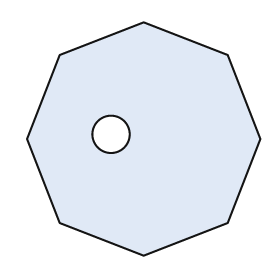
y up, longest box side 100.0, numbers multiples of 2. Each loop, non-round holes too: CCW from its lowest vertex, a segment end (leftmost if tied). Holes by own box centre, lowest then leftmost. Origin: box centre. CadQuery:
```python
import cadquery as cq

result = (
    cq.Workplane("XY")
    .moveTo(0.0, -50.0)
    .lineTo(36.0, -36.0)
    .lineTo(50.0, 0.0)
    .lineTo(36.0, 36.0)
    .lineTo(0.0, 50.0)
    .lineTo(-36.0, 36.0)
    .lineTo(-50.0, 0.0)
    .lineTo(-36.0, -36.0)
    .close()
    .moveTo(-14.0, 2.0)
    .circle(8.0)
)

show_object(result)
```